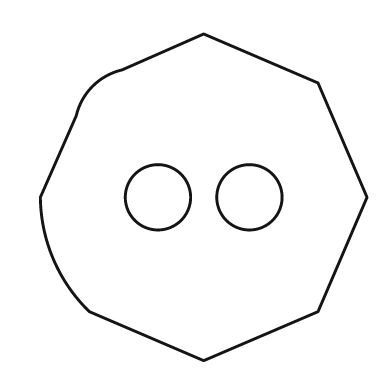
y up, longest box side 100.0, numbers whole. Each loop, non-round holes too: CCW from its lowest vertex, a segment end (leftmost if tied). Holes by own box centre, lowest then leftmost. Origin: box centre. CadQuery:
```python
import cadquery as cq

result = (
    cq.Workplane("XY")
    .moveTo(0.0, -50.0)
    .lineTo(35.0, -35.0)
    .lineTo(50.0, 0.0)
    .lineTo(35.0, 35.0)
    .lineTo(0.0, 50.0)
    .lineTo(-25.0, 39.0)
    .threePointArc((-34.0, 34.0), (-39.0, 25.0))
    .lineTo(-50.0, 0.0)
    .threePointArc((-46.0, -19.0), (-35.0, -35.0))
    .close()
    .moveTo(-14.0, 0.0)
    .circle(10.0)
    .moveTo(14.0, 0.0)
    .circle(10.0)
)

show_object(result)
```